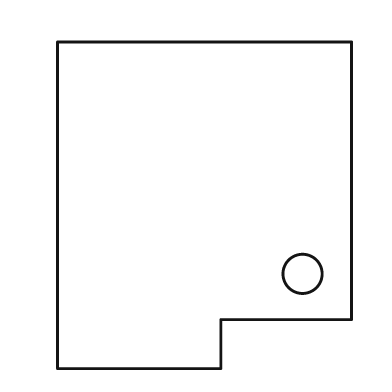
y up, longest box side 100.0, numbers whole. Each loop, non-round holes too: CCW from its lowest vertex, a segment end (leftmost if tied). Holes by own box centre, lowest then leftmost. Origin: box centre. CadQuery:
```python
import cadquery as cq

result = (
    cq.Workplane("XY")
    .moveTo(-45.0, -50.0)
    .lineTo(5.0, -50.0)
    .lineTo(5.0, -35.0)
    .lineTo(45.0, -35.0)
    .lineTo(45.0, 50.0)
    .lineTo(-45.0, 50.0)
    .close()
    .moveTo(30.0, -21.0)
    .circle(6.0)
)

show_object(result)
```